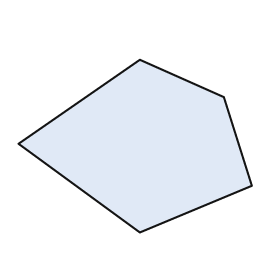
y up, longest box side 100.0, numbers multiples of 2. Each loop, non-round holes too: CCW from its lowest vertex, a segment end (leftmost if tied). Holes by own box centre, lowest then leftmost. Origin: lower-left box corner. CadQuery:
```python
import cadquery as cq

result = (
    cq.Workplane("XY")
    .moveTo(52.0, 0.0)
    .lineTo(100.0, 20.0)
    .lineTo(88.0, 58.0)
    .lineTo(52.0, 74.0)
    .lineTo(0.0, 38.0)
    .close()
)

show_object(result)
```